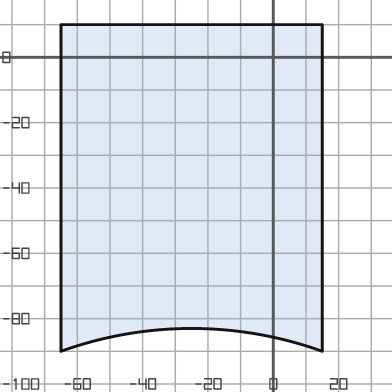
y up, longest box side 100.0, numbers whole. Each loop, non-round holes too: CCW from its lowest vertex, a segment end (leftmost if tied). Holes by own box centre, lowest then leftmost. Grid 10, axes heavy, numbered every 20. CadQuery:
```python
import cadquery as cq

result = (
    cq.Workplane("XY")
    .moveTo(-65.0, -90.0)
    .threePointArc((-25.0, -83.0), (15.0, -90.0))
    .lineTo(15.0, 10.0)
    .lineTo(-65.0, 10.0)
    .close()
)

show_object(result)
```